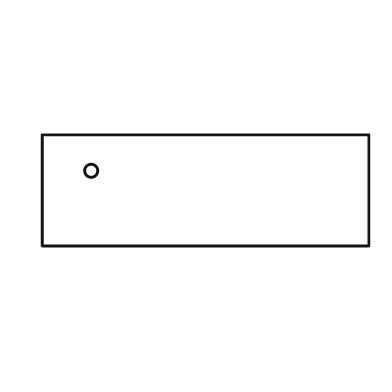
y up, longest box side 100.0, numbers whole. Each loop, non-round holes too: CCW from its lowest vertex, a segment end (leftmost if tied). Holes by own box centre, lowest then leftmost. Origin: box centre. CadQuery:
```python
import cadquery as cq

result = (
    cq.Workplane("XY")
    .moveTo(-50.0, -17.0)
    .lineTo(50.0, -17.0)
    .lineTo(50.0, 17.0)
    .lineTo(-50.0, 17.0)
    .close()
    .moveTo(-35.0, 6.0)
    .circle(2.0)
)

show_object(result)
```